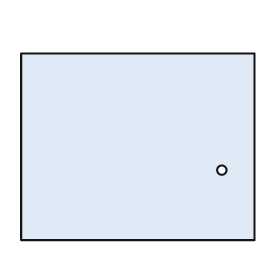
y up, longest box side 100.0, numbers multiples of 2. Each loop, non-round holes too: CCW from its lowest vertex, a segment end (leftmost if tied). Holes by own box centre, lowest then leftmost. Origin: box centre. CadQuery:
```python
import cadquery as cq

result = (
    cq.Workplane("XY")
    .moveTo(-50.0, -40.0)
    .lineTo(50.0, -40.0)
    .lineTo(50.0, 40.0)
    .lineTo(-50.0, 40.0)
    .close()
    .moveTo(36.0, -10.0)
    .circle(2.0)
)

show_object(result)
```